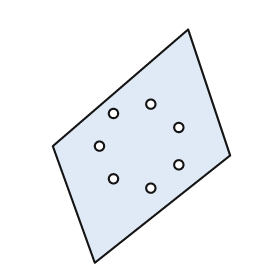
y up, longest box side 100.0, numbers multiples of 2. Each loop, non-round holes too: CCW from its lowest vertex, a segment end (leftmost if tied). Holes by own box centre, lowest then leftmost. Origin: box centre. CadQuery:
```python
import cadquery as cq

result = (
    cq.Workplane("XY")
    .moveTo(-20.0, -50.0)
    .lineTo(38.0, -4.0)
    .lineTo(20.0, 50.0)
    .lineTo(-38.0, 0.0)
    .close()
    .moveTo(4.0, -18.0)
    .circle(2.0)
    .moveTo(-12.0, -14.0)
    .circle(2.0)
    .moveTo(16.0, -8.0)
    .circle(2.0)
    .moveTo(-18.0, 0.0)
    .circle(2.0)
    .moveTo(16.0, 8.0)
    .circle(2.0)
    .moveTo(-12.0, 14.0)
    .circle(2.0)
    .moveTo(4.0, 18.0)
    .circle(2.0)
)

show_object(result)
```